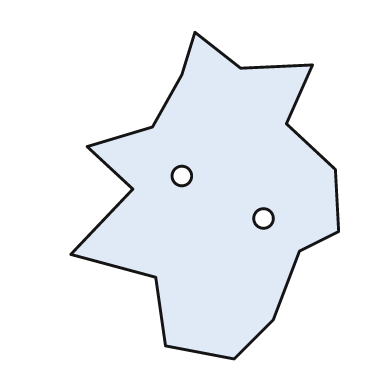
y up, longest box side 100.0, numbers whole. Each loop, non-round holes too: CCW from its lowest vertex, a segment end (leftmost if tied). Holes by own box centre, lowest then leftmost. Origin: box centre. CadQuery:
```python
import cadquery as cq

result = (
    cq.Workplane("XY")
    .moveTo(9.0, -50.0)
    .lineTo(21.0, -38.0)
    .lineTo(29.0, -17.0)
    .lineTo(41.0, -11.0)
    .lineTo(40.0, 8.0)
    .lineTo(25.0, 22.0)
    .lineTo(33.0, 40.0)
    .lineTo(11.0, 39.0)
    .lineTo(-3.0, 50.0)
    .lineTo(-7.0, 37.0)
    .lineTo(-16.0, 21.0)
    .lineTo(-36.0, 15.0)
    .lineTo(-22.0, 2.0)
    .lineTo(-41.0, -18.0)
    .lineTo(-15.0, -25.0)
    .lineTo(-12.0, -46.0)
    .close()
    .moveTo(18.0, -7.0)
    .circle(3.0)
    .moveTo(-7.0, 6.0)
    .circle(3.0)
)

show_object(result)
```